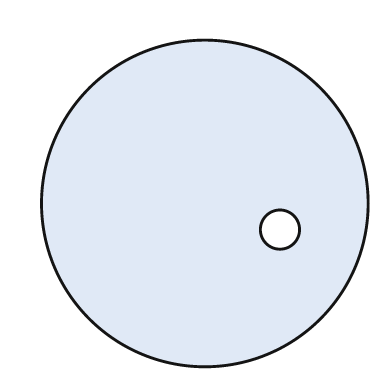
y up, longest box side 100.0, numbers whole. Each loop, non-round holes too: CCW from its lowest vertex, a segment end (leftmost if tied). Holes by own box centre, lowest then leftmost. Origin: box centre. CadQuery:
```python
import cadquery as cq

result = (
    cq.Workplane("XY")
    .moveTo(0.0, 0.0)
    .circle(50.0)
    .moveTo(23.0, -8.0)
    .circle(6.0)
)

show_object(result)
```